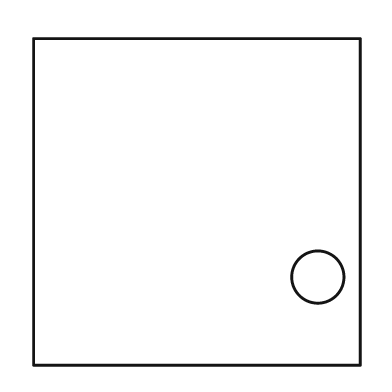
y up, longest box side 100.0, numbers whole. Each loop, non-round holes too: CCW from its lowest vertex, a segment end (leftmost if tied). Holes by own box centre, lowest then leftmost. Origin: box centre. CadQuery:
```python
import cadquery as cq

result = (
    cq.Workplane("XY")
    .moveTo(-50.0, -50.0)
    .lineTo(50.0, -50.0)
    .lineTo(50.0, 50.0)
    .lineTo(-50.0, 50.0)
    .close()
    .moveTo(37.0, -23.0)
    .circle(8.0)
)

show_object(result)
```